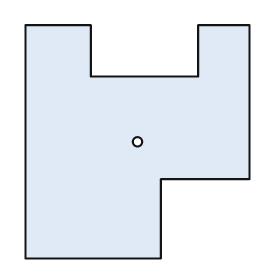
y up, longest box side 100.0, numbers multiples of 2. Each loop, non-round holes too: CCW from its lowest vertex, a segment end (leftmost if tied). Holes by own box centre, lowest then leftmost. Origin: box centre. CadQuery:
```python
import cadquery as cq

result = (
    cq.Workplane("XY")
    .moveTo(-48.0, -50.0)
    .lineTo(10.0, -50.0)
    .lineTo(10.0, -16.0)
    .lineTo(48.0, -16.0)
    .lineTo(48.0, 50.0)
    .lineTo(26.0, 50.0)
    .lineTo(26.0, 28.0)
    .lineTo(-20.0, 28.0)
    .lineTo(-20.0, 50.0)
    .lineTo(-48.0, 50.0)
    .close()
    .moveTo(0.0, 0.0)
    .circle(2.0)
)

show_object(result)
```